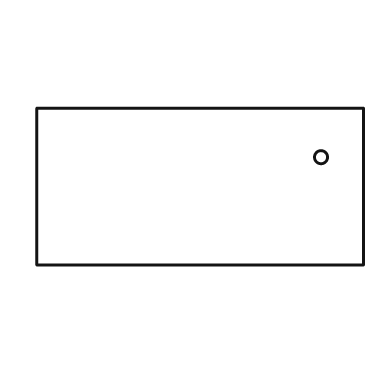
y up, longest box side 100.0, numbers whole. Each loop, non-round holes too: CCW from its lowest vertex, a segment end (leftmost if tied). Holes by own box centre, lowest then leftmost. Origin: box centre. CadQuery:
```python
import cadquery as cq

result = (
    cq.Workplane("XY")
    .moveTo(-50.0, -24.0)
    .lineTo(50.0, -24.0)
    .lineTo(50.0, 24.0)
    .lineTo(-50.0, 24.0)
    .close()
    .moveTo(37.0, 9.0)
    .circle(2.0)
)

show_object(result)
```